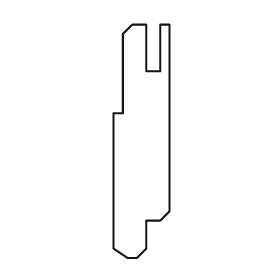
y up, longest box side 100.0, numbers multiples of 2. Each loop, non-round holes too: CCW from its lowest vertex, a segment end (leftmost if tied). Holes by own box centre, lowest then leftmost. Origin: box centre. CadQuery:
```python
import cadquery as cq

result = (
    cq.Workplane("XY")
    .moveTo(-6.0, -50.0)
    .lineTo(-2.0, -50.0)
    .lineTo(2.0, -46.0)
    .lineTo(2.0, -34.0)
    .lineTo(8.0, -34.0)
    .lineTo(12.0, -30.0)
    .lineTo(12.0, 50.0)
    .lineTo(8.0, 50.0)
    .lineTo(8.0, 30.0)
    .lineTo(2.0, 30.0)
    .lineTo(2.0, 50.0)
    .lineTo(-4.0, 50.0)
    .lineTo(-8.0, 46.0)
    .lineTo(-8.0, 12.0)
    .lineTo(-12.0, 12.0)
    .lineTo(-12.0, -46.0)
    .close()
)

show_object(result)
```